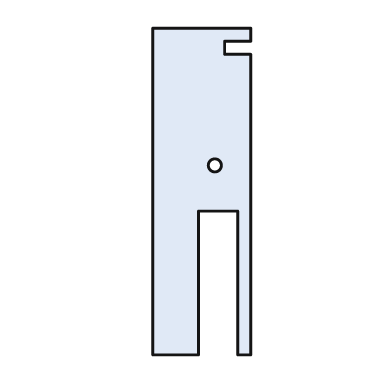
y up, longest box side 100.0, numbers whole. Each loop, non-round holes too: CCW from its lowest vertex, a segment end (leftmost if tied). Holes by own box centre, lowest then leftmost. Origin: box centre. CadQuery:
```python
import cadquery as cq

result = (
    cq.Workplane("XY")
    .moveTo(-15.0, -50.0)
    .lineTo(-1.0, -50.0)
    .lineTo(-1.0, -6.0)
    .lineTo(11.0, -6.0)
    .lineTo(11.0, -50.0)
    .lineTo(15.0, -50.0)
    .lineTo(15.0, 42.0)
    .lineTo(7.0, 42.0)
    .lineTo(7.0, 46.0)
    .lineTo(15.0, 46.0)
    .lineTo(15.0, 50.0)
    .lineTo(-15.0, 50.0)
    .close()
    .moveTo(4.0, 8.0)
    .circle(2.0)
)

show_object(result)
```